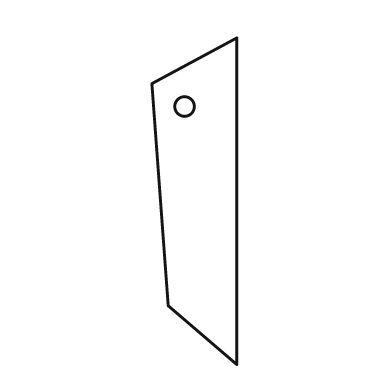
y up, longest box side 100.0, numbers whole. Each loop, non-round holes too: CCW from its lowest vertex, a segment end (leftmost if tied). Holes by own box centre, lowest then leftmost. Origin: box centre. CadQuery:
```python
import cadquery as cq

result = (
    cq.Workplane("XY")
    .moveTo(13.0, -50.0)
    .lineTo(13.0, 50.0)
    .lineTo(-13.0, 36.0)
    .lineTo(-8.0, -32.0)
    .close()
    .moveTo(-3.0, 29.0)
    .circle(3.0)
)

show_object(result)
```